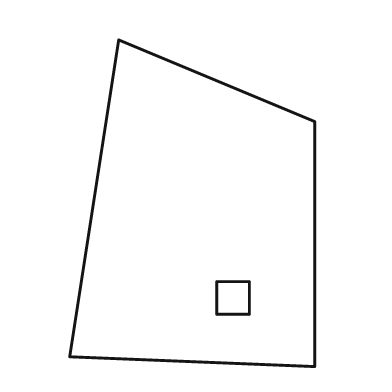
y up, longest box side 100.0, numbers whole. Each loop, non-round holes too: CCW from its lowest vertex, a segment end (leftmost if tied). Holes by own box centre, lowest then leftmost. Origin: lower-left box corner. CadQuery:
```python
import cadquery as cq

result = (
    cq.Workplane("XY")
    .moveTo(75.0, 0.0)
    .lineTo(75.0, 75.0)
    .lineTo(15.0, 100.0)
    .lineTo(0.0, 3.0)
    .close()
    .moveTo(45.0, 16.0)
    .lineTo(55.0, 16.0)
    .lineTo(55.0, 26.0)
    .lineTo(45.0, 26.0)
    .close()
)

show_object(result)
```